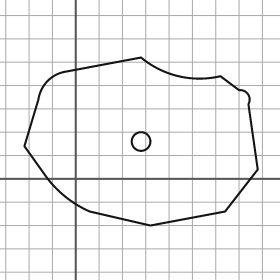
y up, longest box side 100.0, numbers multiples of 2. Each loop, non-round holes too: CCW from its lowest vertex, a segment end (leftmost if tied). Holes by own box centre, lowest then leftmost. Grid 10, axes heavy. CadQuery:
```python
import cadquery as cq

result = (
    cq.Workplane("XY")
    .moveTo(32.0, -20.0)
    .lineTo(64.0, -14.0)
    .lineTo(78.0, 4.0)
    .lineTo(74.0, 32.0)
    .threePointArc((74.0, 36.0), (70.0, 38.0))
    .lineTo(62.0, 44.0)
    .threePointArc((44.0, 44.0), (28.0, 52.0))
    .lineTo(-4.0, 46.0)
    .threePointArc((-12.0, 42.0), (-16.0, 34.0))
    .lineTo(-22.0, 14.0)
    .lineTo(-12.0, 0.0)
    .threePointArc((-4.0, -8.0), (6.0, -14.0))
    .close()
    .moveTo(28.0, 16.0)
    .circle(4.0)
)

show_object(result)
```